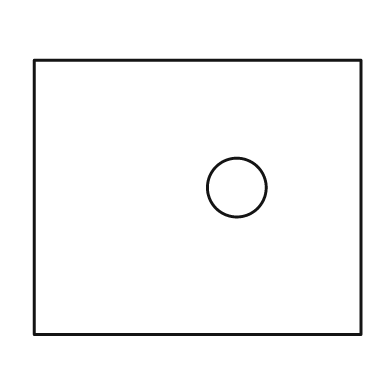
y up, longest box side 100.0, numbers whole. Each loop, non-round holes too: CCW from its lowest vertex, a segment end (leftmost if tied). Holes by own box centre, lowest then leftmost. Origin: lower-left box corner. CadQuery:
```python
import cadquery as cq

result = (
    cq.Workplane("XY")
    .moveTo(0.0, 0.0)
    .lineTo(100.0, 0.0)
    .lineTo(100.0, 84.0)
    .lineTo(0.0, 84.0)
    .close()
    .moveTo(62.0, 45.0)
    .circle(9.0)
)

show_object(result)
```